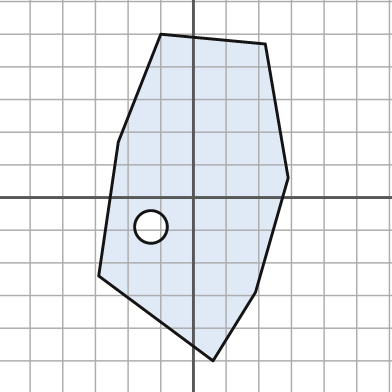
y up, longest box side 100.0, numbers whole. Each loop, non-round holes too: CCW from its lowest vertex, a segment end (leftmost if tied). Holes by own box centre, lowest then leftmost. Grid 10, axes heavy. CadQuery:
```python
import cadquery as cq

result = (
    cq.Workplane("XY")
    .moveTo(6.0, -50.0)
    .lineTo(19.0, -29.0)
    .lineTo(29.0, 6.0)
    .lineTo(22.0, 47.0)
    .lineTo(-10.0, 50.0)
    .lineTo(-23.0, 17.0)
    .lineTo(-29.0, -24.0)
    .close()
    .moveTo(-13.0, -9.0)
    .circle(5.0)
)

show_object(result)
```